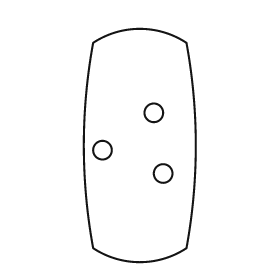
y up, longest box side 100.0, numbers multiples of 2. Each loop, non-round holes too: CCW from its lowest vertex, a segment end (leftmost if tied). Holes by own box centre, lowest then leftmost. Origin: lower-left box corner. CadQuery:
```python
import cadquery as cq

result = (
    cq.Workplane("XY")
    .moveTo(4.0, 6.0)
    .threePointArc((24.0, 0.0), (44.0, 6.0))
    .threePointArc((48.0, 50.0), (44.0, 94.0))
    .threePointArc((24.0, 100.0), (4.0, 94.0))
    .threePointArc((0.0, 50.0), (4.0, 6.0))
    .close()
    .moveTo(34.0, 38.0)
    .circle(4.0)
    .moveTo(8.0, 48.0)
    .circle(4.0)
    .moveTo(30.0, 64.0)
    .circle(4.0)
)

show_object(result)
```